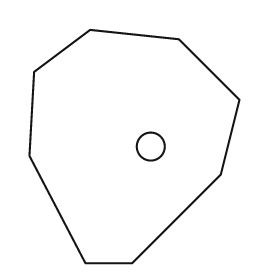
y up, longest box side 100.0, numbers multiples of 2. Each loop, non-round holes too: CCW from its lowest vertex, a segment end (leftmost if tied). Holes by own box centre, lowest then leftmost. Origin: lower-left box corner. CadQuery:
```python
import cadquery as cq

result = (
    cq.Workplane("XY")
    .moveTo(24.0, 0.0)
    .lineTo(44.0, 0.0)
    .lineTo(82.0, 38.0)
    .lineTo(90.0, 70.0)
    .lineTo(64.0, 96.0)
    .lineTo(26.0, 100.0)
    .lineTo(2.0, 82.0)
    .lineTo(0.0, 46.0)
    .close()
    .moveTo(52.0, 50.0)
    .circle(6.0)
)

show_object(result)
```